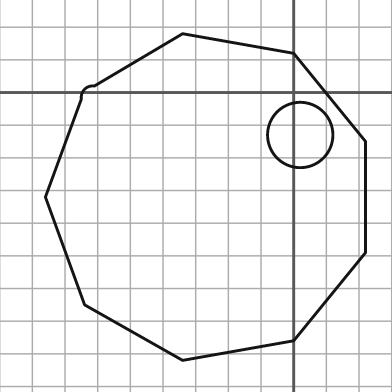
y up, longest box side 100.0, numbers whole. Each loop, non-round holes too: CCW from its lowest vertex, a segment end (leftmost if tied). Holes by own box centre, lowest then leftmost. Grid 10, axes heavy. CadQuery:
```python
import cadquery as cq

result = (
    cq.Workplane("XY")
    .moveTo(-34.0, -82.0)
    .lineTo(0.0, -76.0)
    .lineTo(22.0, -49.0)
    .lineTo(22.0, -15.0)
    .lineTo(0.0, 12.0)
    .lineTo(-34.0, 18.0)
    .lineTo(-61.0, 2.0)
    .threePointArc((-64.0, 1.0), (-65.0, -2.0))
    .lineTo(-76.0, -32.0)
    .lineTo(-64.0, -65.0)
    .close()
    .moveTo(2.0, -13.0)
    .circle(10.0)
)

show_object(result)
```